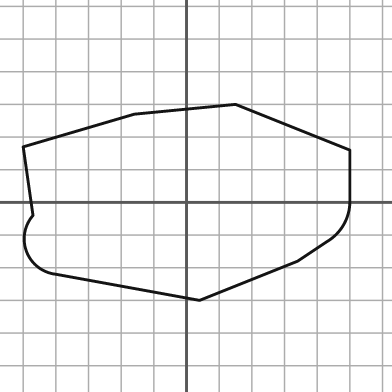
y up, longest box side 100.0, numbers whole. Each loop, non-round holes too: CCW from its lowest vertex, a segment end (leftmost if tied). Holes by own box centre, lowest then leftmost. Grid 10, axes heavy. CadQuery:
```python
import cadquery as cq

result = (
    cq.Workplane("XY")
    .moveTo(4.0, -30.0)
    .lineTo(34.0, -18.0)
    .lineTo(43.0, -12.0)
    .threePointArc((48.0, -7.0), (50.0, 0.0))
    .lineTo(50.0, 16.0)
    .lineTo(15.0, 30.0)
    .lineTo(-16.0, 27.0)
    .lineTo(-50.0, 17.0)
    .lineTo(-47.0, -4.0)
    .threePointArc((-49.0, -15.0), (-40.0, -22.0))
    .close()
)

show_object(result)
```